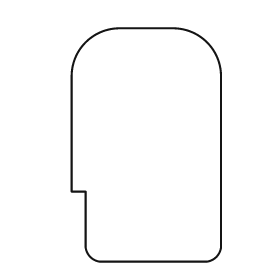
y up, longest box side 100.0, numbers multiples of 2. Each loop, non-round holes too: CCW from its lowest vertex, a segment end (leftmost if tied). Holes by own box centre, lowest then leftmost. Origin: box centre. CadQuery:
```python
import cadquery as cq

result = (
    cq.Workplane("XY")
    .moveTo(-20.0, -50.0)
    .lineTo(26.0, -50.0)
    .threePointArc((30.0, -48.0), (32.0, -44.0))
    .lineTo(32.0, 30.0)
    .threePointArc((26.0, 44.0), (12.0, 50.0))
    .lineTo(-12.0, 50.0)
    .threePointArc((-26.0, 44.0), (-32.0, 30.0))
    .lineTo(-32.0, -20.0)
    .lineTo(-26.0, -20.0)
    .lineTo(-26.0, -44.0)
    .threePointArc((-24.0, -48.0), (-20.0, -50.0))
    .close()
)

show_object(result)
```